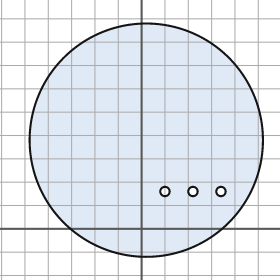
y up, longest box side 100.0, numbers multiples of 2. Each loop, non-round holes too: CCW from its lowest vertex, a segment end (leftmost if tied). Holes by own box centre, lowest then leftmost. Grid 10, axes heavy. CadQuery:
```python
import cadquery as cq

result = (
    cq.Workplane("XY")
    .moveTo(2.0, 38.0)
    .circle(50.0)
    .moveTo(10.0, 16.0)
    .circle(2.0)
    .moveTo(22.0, 16.0)
    .circle(2.0)
    .moveTo(34.0, 16.0)
    .circle(2.0)
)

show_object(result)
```